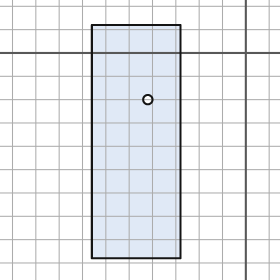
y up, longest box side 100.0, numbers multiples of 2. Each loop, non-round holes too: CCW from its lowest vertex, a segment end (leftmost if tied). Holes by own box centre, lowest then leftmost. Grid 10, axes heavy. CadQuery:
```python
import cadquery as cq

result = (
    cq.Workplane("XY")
    .moveTo(-66.0, -88.0)
    .lineTo(-28.0, -88.0)
    .lineTo(-28.0, 12.0)
    .lineTo(-66.0, 12.0)
    .close()
    .moveTo(-42.0, -20.0)
    .circle(2.0)
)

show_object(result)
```